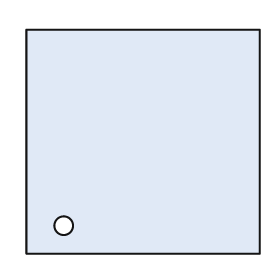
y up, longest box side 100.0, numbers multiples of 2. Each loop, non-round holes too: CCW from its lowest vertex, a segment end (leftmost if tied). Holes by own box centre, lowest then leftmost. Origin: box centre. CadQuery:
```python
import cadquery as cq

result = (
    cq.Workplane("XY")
    .moveTo(-50.0, -48.0)
    .lineTo(50.0, -48.0)
    .lineTo(50.0, 48.0)
    .lineTo(-50.0, 48.0)
    .close()
    .moveTo(-34.0, -36.0)
    .circle(4.0)
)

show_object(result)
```